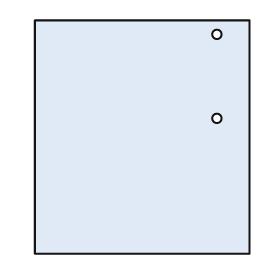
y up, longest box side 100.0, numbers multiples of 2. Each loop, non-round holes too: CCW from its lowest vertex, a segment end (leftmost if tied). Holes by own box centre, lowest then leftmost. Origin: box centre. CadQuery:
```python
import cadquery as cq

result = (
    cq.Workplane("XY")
    .moveTo(-46.0, -50.0)
    .lineTo(46.0, -50.0)
    .lineTo(46.0, 50.0)
    .lineTo(-46.0, 50.0)
    .close()
    .moveTo(32.0, 8.0)
    .circle(2.0)
    .moveTo(32.0, 44.0)
    .circle(2.0)
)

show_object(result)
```